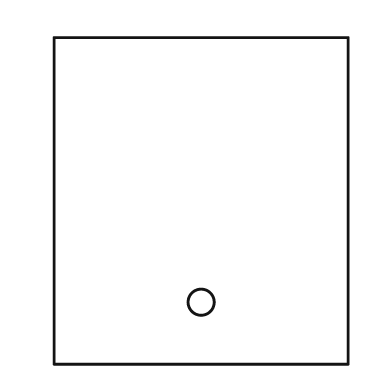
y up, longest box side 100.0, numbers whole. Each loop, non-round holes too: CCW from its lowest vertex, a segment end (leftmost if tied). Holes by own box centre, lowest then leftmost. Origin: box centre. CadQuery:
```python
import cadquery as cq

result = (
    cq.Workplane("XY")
    .moveTo(-45.0, -50.0)
    .lineTo(45.0, -50.0)
    .lineTo(45.0, 50.0)
    .lineTo(-45.0, 50.0)
    .close()
    .moveTo(0.0, -31.0)
    .circle(4.0)
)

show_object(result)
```